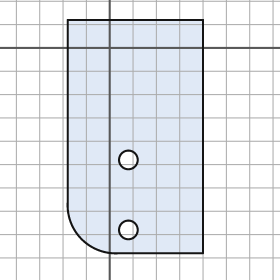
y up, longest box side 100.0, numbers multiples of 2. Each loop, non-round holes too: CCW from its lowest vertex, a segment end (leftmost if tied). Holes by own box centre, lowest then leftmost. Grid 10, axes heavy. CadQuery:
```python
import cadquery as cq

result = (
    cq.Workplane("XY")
    .moveTo(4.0, -88.0)
    .lineTo(40.0, -88.0)
    .lineTo(40.0, 12.0)
    .lineTo(-18.0, 12.0)
    .lineTo(-18.0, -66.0)
    .threePointArc((-12.0, -82.0), (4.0, -88.0))
    .close()
    .moveTo(8.0, -78.0)
    .circle(4.0)
    .moveTo(8.0, -48.0)
    .circle(4.0)
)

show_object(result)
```